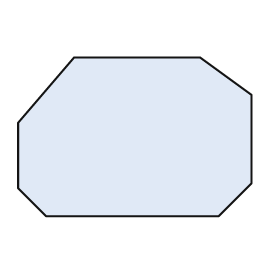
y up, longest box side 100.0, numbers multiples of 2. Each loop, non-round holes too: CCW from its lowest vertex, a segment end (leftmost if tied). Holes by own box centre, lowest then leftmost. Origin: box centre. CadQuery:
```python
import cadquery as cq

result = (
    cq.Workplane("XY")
    .moveTo(-38.0, -34.0)
    .lineTo(36.0, -34.0)
    .lineTo(50.0, -20.0)
    .lineTo(50.0, 18.0)
    .lineTo(28.0, 34.0)
    .lineTo(-26.0, 34.0)
    .lineTo(-50.0, 6.0)
    .lineTo(-50.0, -22.0)
    .close()
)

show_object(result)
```